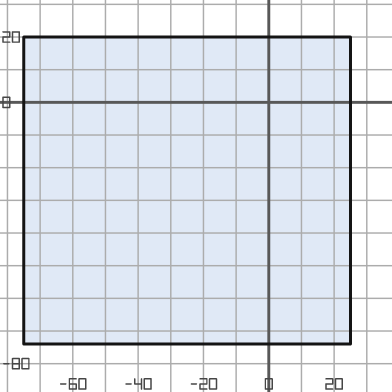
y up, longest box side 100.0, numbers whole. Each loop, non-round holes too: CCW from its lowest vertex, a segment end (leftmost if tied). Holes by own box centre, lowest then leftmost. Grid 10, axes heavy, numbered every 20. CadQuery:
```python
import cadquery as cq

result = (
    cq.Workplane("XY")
    .moveTo(-75.0, -74.0)
    .lineTo(25.0, -74.0)
    .lineTo(25.0, 20.0)
    .lineTo(-75.0, 20.0)
    .close()
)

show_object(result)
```